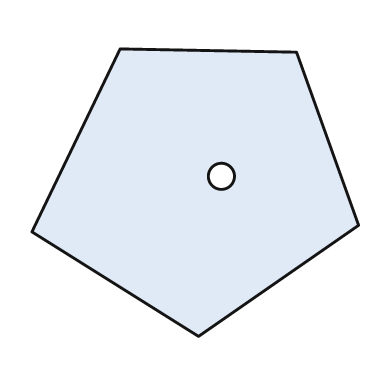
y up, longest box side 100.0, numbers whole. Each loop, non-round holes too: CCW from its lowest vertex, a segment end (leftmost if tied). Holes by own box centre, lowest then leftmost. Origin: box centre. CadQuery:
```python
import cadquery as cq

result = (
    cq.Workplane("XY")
    .moveTo(1.0, -44.0)
    .lineTo(50.0, -10.0)
    .lineTo(31.0, 43.0)
    .lineTo(-23.0, 44.0)
    .lineTo(-50.0, -12.0)
    .close()
    .moveTo(8.0, 5.0)
    .circle(4.0)
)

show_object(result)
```